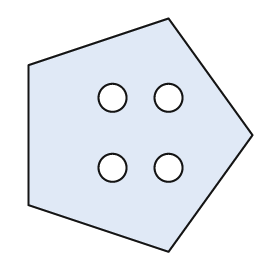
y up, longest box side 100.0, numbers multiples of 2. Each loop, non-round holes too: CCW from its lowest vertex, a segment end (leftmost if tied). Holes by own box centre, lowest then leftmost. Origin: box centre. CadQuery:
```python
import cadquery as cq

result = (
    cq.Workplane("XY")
    .moveTo(12.0, -50.0)
    .lineTo(48.0, 0.0)
    .lineTo(12.0, 50.0)
    .lineTo(-48.0, 30.0)
    .lineTo(-48.0, -30.0)
    .close()
    .moveTo(-12.0, -14.0)
    .circle(6.0)
    .moveTo(12.0, -14.0)
    .circle(6.0)
    .moveTo(-12.0, 16.0)
    .circle(6.0)
    .moveTo(12.0, 16.0)
    .circle(6.0)
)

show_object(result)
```